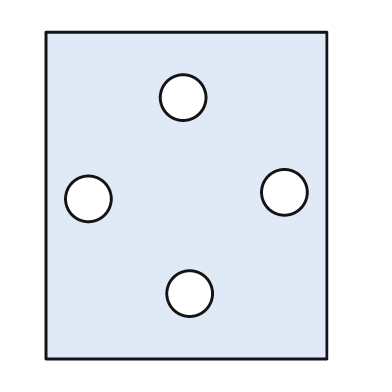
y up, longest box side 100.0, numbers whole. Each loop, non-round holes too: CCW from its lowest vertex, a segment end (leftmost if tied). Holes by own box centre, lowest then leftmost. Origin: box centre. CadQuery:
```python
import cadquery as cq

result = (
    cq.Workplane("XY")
    .moveTo(-43.0, -50.0)
    .lineTo(43.0, -50.0)
    .lineTo(43.0, 50.0)
    .lineTo(-43.0, 50.0)
    .close()
    .moveTo(1.0, -30.0)
    .circle(7.0)
    .moveTo(-30.0, -1.0)
    .circle(7.0)
    .moveTo(30.0, 1.0)
    .circle(7.0)
    .moveTo(-1.0, 30.0)
    .circle(7.0)
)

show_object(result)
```